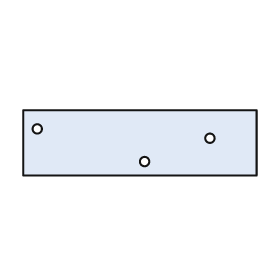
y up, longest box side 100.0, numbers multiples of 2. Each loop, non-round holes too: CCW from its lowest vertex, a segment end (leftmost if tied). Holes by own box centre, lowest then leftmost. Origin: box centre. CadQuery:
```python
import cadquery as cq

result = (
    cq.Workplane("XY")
    .moveTo(-50.0, -14.0)
    .lineTo(50.0, -14.0)
    .lineTo(50.0, 14.0)
    .lineTo(-50.0, 14.0)
    .close()
    .moveTo(2.0, -8.0)
    .circle(2.0)
    .moveTo(30.0, 2.0)
    .circle(2.0)
    .moveTo(-44.0, 6.0)
    .circle(2.0)
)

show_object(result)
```